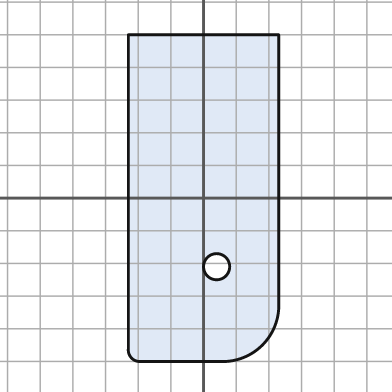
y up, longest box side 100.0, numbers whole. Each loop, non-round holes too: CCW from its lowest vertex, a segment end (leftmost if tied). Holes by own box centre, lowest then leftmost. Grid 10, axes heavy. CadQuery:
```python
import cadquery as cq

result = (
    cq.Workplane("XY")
    .moveTo(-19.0, -50.0)
    .lineTo(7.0, -50.0)
    .threePointArc((18.0, -45.0), (23.0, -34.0))
    .lineTo(23.0, 50.0)
    .lineTo(-23.0, 50.0)
    .lineTo(-23.0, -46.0)
    .threePointArc((-22.0, -49.0), (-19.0, -50.0))
    .close()
    .moveTo(4.0, -21.0)
    .circle(4.0)
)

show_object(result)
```